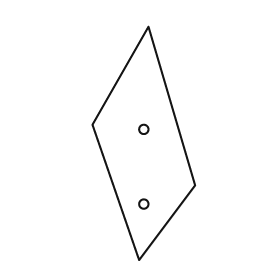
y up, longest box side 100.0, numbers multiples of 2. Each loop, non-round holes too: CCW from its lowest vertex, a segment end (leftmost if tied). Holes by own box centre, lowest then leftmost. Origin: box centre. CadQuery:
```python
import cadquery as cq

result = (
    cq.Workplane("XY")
    .moveTo(-2.0, -50.0)
    .lineTo(22.0, -18.0)
    .lineTo(2.0, 50.0)
    .lineTo(-22.0, 8.0)
    .close()
    .moveTo(0.0, -26.0)
    .circle(2.0)
    .moveTo(0.0, 6.0)
    .circle(2.0)
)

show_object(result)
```